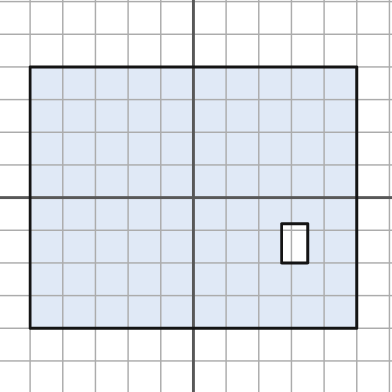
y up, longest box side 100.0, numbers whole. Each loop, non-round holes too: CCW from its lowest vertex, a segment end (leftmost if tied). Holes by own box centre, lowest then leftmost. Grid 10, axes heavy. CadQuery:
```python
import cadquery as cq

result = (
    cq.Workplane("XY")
    .moveTo(-50.0, -40.0)
    .lineTo(50.0, -40.0)
    .lineTo(50.0, 40.0)
    .lineTo(-50.0, 40.0)
    .close()
    .moveTo(27.0, -20.0)
    .lineTo(35.0, -20.0)
    .lineTo(35.0, -8.0)
    .lineTo(27.0, -8.0)
    .close()
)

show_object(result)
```